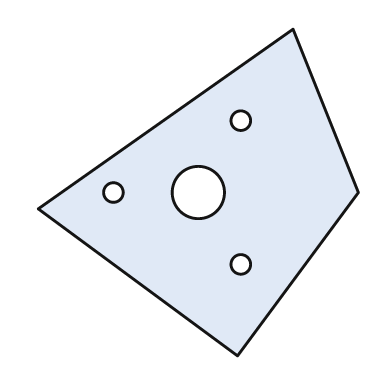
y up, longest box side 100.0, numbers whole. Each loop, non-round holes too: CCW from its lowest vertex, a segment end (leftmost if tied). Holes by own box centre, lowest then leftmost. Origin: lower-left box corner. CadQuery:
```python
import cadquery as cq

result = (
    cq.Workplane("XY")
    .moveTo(61.0, 0.0)
    .lineTo(98.0, 50.0)
    .lineTo(78.0, 100.0)
    .lineTo(0.0, 45.0)
    .close()
    .moveTo(62.0, 28.0)
    .circle(3.0)
    .moveTo(23.0, 50.0)
    .circle(3.0)
    .moveTo(49.0, 50.0)
    .circle(8.0)
    .moveTo(62.0, 72.0)
    .circle(3.0)
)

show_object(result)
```